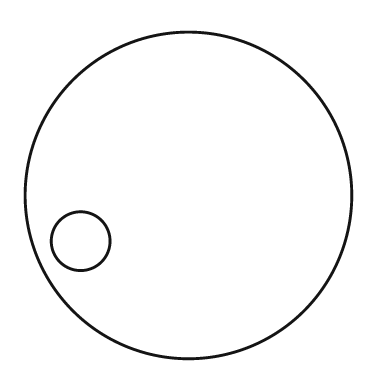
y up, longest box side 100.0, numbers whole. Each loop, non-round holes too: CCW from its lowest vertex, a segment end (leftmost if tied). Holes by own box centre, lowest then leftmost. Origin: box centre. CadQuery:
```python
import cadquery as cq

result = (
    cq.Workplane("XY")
    .moveTo(0.0, 0.0)
    .circle(50.0)
    .moveTo(-33.0, -14.0)
    .circle(9.0)
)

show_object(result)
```